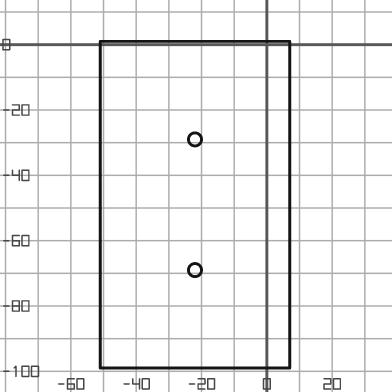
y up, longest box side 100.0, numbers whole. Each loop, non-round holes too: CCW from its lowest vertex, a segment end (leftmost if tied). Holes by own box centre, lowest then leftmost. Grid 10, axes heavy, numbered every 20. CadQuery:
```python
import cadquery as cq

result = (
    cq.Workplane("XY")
    .moveTo(-51.0, -99.0)
    .lineTo(7.0, -99.0)
    .lineTo(7.0, 1.0)
    .lineTo(-51.0, 1.0)
    .close()
    .moveTo(-22.0, -69.0)
    .circle(2.0)
    .moveTo(-22.0, -29.0)
    .circle(2.0)
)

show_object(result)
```